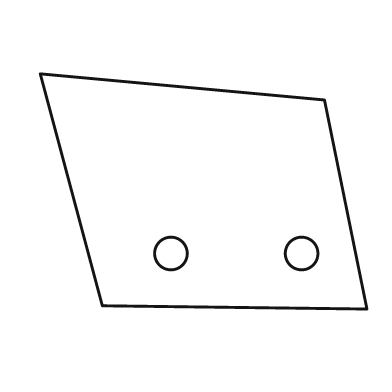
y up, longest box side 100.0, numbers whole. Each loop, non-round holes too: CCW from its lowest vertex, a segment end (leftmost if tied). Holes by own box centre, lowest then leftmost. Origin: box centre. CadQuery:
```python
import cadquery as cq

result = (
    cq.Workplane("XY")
    .moveTo(50.0, -36.0)
    .lineTo(37.0, 28.0)
    .lineTo(-50.0, 36.0)
    .lineTo(-31.0, -35.0)
    .close()
    .moveTo(-10.0, -19.0)
    .circle(5.0)
    .moveTo(30.0, -19.0)
    .circle(5.0)
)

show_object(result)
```